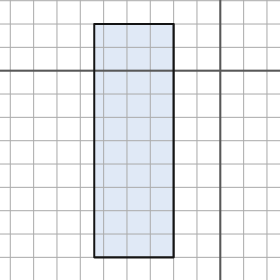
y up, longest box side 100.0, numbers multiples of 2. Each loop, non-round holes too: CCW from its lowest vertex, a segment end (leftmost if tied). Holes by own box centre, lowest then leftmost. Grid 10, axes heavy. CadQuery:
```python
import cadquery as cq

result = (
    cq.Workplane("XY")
    .moveTo(-54.0, -80.0)
    .lineTo(-20.0, -80.0)
    .lineTo(-20.0, 20.0)
    .lineTo(-54.0, 20.0)
    .close()
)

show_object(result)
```